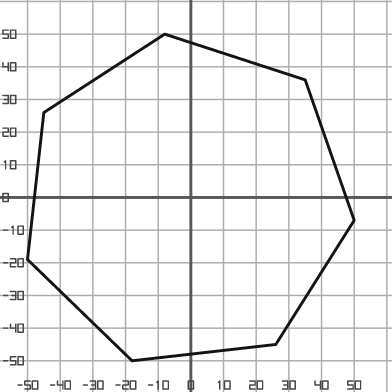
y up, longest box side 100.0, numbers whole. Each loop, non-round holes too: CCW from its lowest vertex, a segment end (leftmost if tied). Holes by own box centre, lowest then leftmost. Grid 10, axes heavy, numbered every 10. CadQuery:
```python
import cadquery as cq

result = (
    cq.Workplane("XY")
    .moveTo(-18.0, -50.0)
    .lineTo(26.0, -45.0)
    .lineTo(50.0, -7.0)
    .lineTo(35.0, 36.0)
    .lineTo(-8.0, 50.0)
    .lineTo(-45.0, 26.0)
    .lineTo(-50.0, -19.0)
    .close()
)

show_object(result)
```